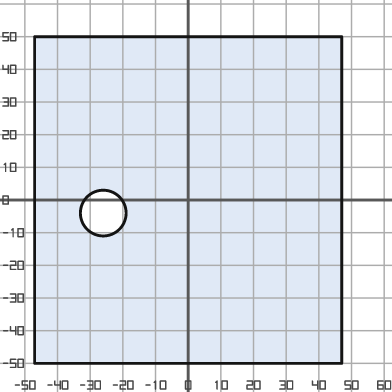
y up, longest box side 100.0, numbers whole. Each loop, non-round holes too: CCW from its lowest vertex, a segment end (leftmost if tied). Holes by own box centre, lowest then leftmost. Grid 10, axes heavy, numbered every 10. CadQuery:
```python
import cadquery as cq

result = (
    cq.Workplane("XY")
    .moveTo(-47.0, -50.0)
    .lineTo(47.0, -50.0)
    .lineTo(47.0, 50.0)
    .lineTo(-47.0, 50.0)
    .close()
    .moveTo(-26.0, -4.0)
    .circle(7.0)
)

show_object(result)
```